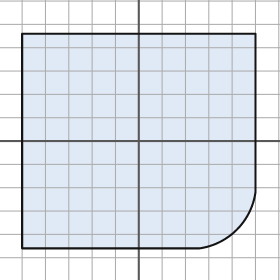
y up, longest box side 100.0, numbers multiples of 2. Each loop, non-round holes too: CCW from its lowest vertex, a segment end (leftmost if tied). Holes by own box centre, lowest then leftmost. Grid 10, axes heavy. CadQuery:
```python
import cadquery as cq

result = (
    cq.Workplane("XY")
    .moveTo(-50.0, -46.0)
    .lineTo(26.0, -46.0)
    .threePointArc((42.0, -38.0), (50.0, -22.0))
    .lineTo(50.0, 46.0)
    .lineTo(-50.0, 46.0)
    .close()
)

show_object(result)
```